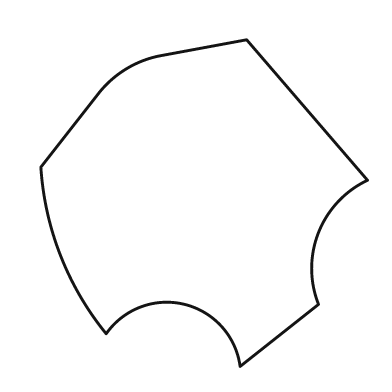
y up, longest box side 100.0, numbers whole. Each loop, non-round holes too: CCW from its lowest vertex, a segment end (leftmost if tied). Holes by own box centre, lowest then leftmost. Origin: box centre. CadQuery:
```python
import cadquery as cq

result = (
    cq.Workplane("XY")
    .moveTo(11.0, -50.0)
    .lineTo(35.0, -31.0)
    .threePointArc((35.0, -9.0), (50.0, 7.0))
    .lineTo(13.0, 50.0)
    .lineTo(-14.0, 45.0)
    .threePointArc((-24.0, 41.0), (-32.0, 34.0))
    .lineTo(-50.0, 11.0)
    .threePointArc((-44.0, -16.0), (-30.0, -40.0))
    .threePointArc((-6.0, -31.0), (11.0, -50.0))
    .close()
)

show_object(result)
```